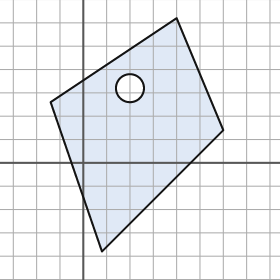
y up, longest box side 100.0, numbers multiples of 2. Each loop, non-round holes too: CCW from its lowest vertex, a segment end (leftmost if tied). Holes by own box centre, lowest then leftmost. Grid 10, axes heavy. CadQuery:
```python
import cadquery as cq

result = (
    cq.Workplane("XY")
    .moveTo(8.0, -38.0)
    .lineTo(60.0, 14.0)
    .lineTo(40.0, 62.0)
    .lineTo(-14.0, 26.0)
    .close()
    .moveTo(20.0, 32.0)
    .circle(6.0)
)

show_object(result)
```